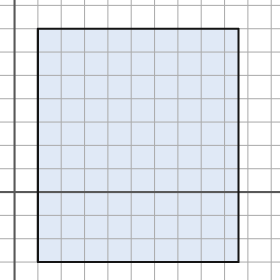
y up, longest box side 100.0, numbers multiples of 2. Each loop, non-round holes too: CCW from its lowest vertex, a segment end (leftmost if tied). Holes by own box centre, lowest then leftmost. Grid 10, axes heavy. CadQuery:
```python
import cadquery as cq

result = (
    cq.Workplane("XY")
    .moveTo(10.0, -30.0)
    .lineTo(96.0, -30.0)
    .lineTo(96.0, 70.0)
    .lineTo(10.0, 70.0)
    .close()
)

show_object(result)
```